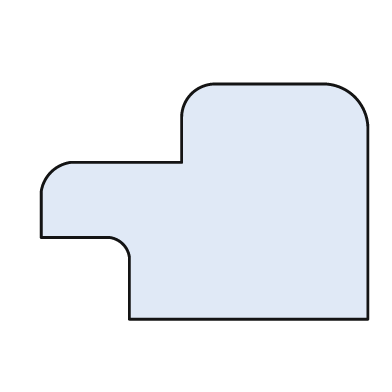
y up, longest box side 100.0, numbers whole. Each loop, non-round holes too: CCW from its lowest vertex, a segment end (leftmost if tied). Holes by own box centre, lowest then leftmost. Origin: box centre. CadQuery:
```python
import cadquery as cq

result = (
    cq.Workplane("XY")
    .moveTo(-23.0, -36.0)
    .lineTo(50.0, -36.0)
    .lineTo(50.0, 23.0)
    .threePointArc((46.0, 32.0), (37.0, 36.0))
    .lineTo(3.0, 36.0)
    .threePointArc((-4.0, 33.0), (-7.0, 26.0))
    .lineTo(-7.0, 12.0)
    .lineTo(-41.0, 12.0)
    .threePointArc((-47.0, 9.0), (-50.0, 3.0))
    .lineTo(-50.0, -11.0)
    .lineTo(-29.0, -11.0)
    .threePointArc((-25.0, -13.0), (-23.0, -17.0))
    .close()
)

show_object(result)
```